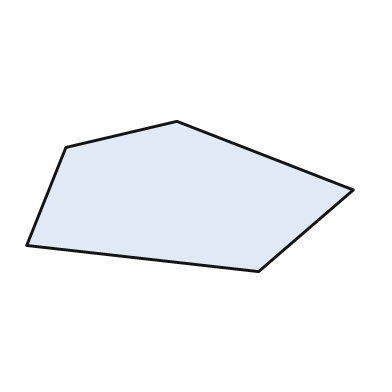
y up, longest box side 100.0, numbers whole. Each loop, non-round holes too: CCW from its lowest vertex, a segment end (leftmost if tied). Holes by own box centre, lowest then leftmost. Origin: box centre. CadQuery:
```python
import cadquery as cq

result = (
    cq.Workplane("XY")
    .moveTo(21.0, -23.0)
    .lineTo(50.0, 2.0)
    .lineTo(-4.0, 23.0)
    .lineTo(-38.0, 15.0)
    .lineTo(-50.0, -15.0)
    .close()
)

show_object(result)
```